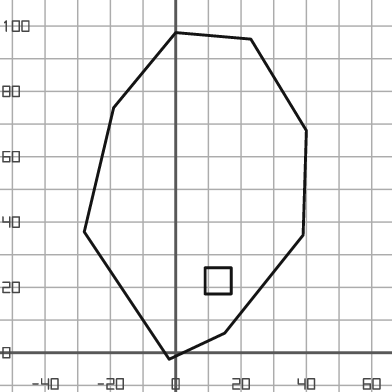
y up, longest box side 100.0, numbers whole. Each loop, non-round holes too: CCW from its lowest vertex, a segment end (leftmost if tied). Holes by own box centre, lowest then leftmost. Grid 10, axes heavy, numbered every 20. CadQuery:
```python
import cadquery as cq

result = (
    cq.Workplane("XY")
    .moveTo(-2.0, -2.0)
    .lineTo(15.0, 6.0)
    .lineTo(39.0, 36.0)
    .lineTo(40.0, 68.0)
    .lineTo(23.0, 96.0)
    .lineTo(0.0, 98.0)
    .lineTo(-19.0, 75.0)
    .lineTo(-28.0, 37.0)
    .close()
    .moveTo(9.0, 18.0)
    .lineTo(17.0, 18.0)
    .lineTo(17.0, 26.0)
    .lineTo(9.0, 26.0)
    .close()
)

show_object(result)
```